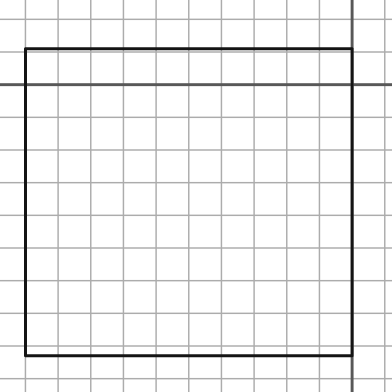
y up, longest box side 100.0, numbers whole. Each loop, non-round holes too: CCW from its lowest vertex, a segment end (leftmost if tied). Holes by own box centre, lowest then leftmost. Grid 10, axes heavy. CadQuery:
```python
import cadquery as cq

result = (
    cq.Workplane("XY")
    .moveTo(-100.0, -83.0)
    .lineTo(0.0, -83.0)
    .lineTo(0.0, 11.0)
    .lineTo(-100.0, 11.0)
    .close()
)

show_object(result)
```